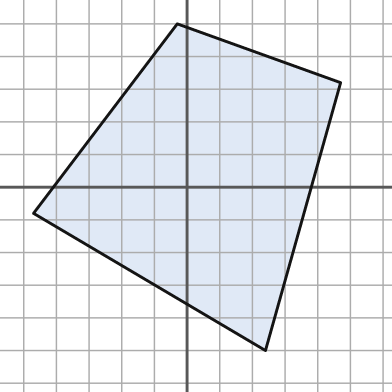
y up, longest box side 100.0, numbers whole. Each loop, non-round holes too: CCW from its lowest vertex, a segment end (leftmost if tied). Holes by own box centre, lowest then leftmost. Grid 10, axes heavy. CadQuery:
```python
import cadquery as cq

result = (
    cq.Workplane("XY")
    .moveTo(24.0, -50.0)
    .lineTo(47.0, 32.0)
    .lineTo(-3.0, 50.0)
    .lineTo(-47.0, -8.0)
    .close()
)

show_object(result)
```